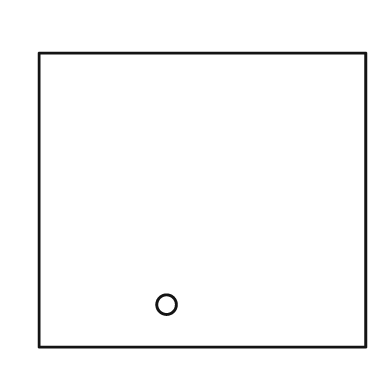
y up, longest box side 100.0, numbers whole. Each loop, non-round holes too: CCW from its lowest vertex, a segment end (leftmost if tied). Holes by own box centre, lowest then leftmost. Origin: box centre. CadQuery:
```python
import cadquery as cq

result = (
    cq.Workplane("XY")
    .moveTo(-50.0, -45.0)
    .lineTo(50.0, -45.0)
    .lineTo(50.0, 45.0)
    .lineTo(-50.0, 45.0)
    .close()
    .moveTo(-11.0, -32.0)
    .circle(3.0)
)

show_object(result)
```